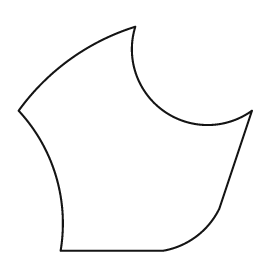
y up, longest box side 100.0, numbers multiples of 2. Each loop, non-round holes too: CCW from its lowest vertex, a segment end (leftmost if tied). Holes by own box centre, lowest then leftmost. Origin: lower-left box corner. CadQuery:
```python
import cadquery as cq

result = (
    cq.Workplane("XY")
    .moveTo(18.0, 0.0)
    .lineTo(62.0, 0.0)
    .threePointArc((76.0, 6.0), (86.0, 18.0))
    .lineTo(100.0, 60.0)
    .threePointArc((62.0, 60.0), (50.0, 96.0))
    .threePointArc((22.0, 82.0), (0.0, 60.0))
    .threePointArc((16.0, 32.0), (18.0, 0.0))
    .close()
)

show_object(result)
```